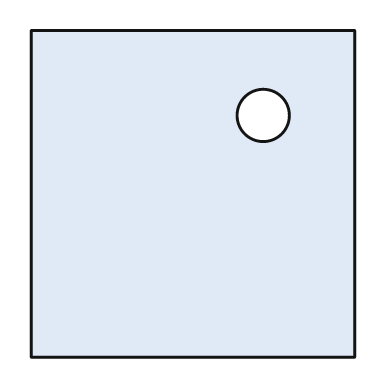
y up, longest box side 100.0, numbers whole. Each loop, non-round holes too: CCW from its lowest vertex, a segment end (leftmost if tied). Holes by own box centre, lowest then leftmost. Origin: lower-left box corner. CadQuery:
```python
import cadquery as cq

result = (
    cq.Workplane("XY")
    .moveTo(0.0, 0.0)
    .lineTo(99.0, 0.0)
    .lineTo(99.0, 100.0)
    .lineTo(0.0, 100.0)
    .close()
    .moveTo(71.0, 74.0)
    .circle(8.0)
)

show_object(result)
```